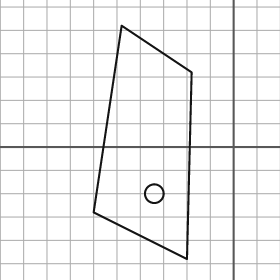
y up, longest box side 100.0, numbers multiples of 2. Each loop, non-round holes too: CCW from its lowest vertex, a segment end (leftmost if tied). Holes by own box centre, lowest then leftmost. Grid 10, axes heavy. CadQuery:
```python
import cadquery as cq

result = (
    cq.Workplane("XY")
    .moveTo(-20.0, -48.0)
    .lineTo(-18.0, 32.0)
    .lineTo(-48.0, 52.0)
    .lineTo(-60.0, -28.0)
    .close()
    .moveTo(-34.0, -20.0)
    .circle(4.0)
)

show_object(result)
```